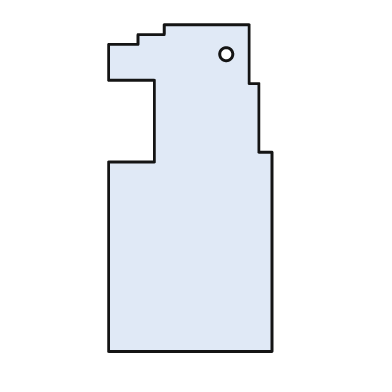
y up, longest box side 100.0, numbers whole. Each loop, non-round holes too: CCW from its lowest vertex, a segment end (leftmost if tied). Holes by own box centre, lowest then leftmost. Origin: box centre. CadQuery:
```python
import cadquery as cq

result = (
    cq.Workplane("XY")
    .moveTo(-25.0, -50.0)
    .lineTo(25.0, -50.0)
    .lineTo(25.0, 11.0)
    .lineTo(21.0, 11.0)
    .lineTo(21.0, 32.0)
    .lineTo(18.0, 32.0)
    .lineTo(18.0, 50.0)
    .lineTo(-8.0, 50.0)
    .lineTo(-8.0, 47.0)
    .lineTo(-16.0, 47.0)
    .lineTo(-16.0, 44.0)
    .lineTo(-25.0, 44.0)
    .lineTo(-25.0, 33.0)
    .lineTo(-11.0, 33.0)
    .lineTo(-11.0, 8.0)
    .lineTo(-25.0, 8.0)
    .close()
    .moveTo(11.0, 41.0)
    .circle(2.0)
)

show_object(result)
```